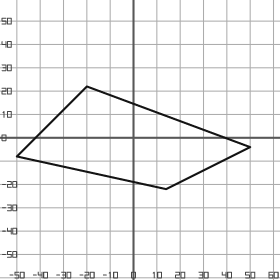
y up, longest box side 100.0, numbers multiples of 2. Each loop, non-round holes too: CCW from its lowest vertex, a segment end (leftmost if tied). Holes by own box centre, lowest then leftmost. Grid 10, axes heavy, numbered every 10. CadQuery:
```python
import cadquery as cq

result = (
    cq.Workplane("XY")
    .moveTo(14.0, -22.0)
    .lineTo(50.0, -4.0)
    .lineTo(-20.0, 22.0)
    .lineTo(-50.0, -8.0)
    .close()
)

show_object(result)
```